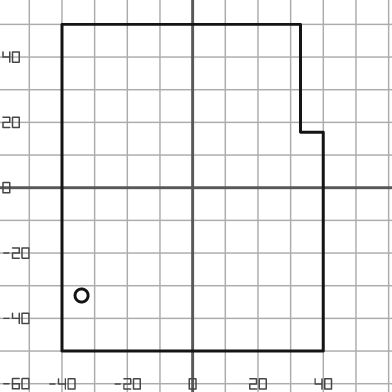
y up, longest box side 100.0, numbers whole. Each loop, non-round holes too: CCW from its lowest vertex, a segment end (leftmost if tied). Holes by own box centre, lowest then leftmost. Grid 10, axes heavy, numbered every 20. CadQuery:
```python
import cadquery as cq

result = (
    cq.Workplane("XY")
    .moveTo(-40.0, -50.0)
    .lineTo(40.0, -50.0)
    .lineTo(40.0, 17.0)
    .lineTo(33.0, 17.0)
    .lineTo(33.0, 50.0)
    .lineTo(-40.0, 50.0)
    .close()
    .moveTo(-34.0, -33.0)
    .circle(2.0)
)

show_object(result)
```